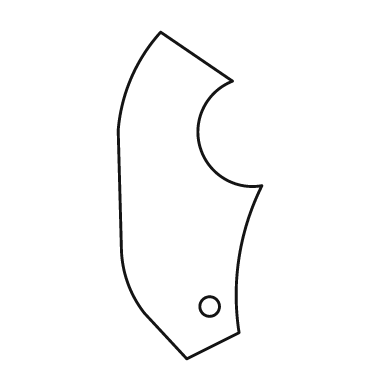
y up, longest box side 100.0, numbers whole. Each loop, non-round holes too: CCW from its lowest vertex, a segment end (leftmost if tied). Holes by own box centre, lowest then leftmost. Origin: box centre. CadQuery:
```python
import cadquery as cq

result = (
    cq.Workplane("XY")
    .moveTo(-1.0, -50.0)
    .lineTo(15.0, -42.0)
    .threePointArc((15.0, -19.0), (22.0, 3.0))
    .threePointArc((3.0, 15.0), (13.0, 35.0))
    .lineTo(-9.0, 50.0)
    .threePointArc((-18.0, 36.0), (-22.0, 20.0))
    .lineTo(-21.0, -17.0)
    .threePointArc((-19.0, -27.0), (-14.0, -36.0))
    .close()
    .moveTo(6.0, -34.0)
    .circle(3.0)
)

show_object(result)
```